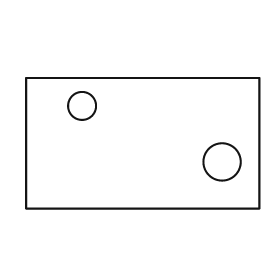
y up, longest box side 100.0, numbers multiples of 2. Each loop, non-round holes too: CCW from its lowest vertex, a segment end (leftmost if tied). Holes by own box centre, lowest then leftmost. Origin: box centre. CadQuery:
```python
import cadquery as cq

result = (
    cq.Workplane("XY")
    .moveTo(-50.0, -28.0)
    .lineTo(50.0, -28.0)
    .lineTo(50.0, 28.0)
    .lineTo(-50.0, 28.0)
    .close()
    .moveTo(34.0, -8.0)
    .circle(8.0)
    .moveTo(-26.0, 16.0)
    .circle(6.0)
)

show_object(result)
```